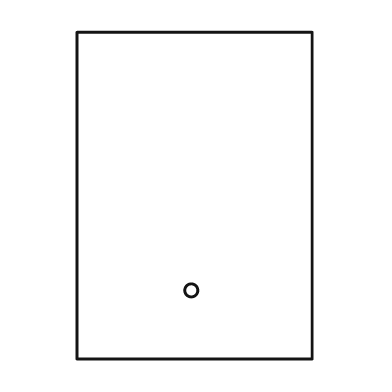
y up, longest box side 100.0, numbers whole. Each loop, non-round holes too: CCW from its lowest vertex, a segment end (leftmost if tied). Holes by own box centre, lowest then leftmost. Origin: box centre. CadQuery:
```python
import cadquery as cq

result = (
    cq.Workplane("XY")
    .moveTo(-36.0, -50.0)
    .lineTo(36.0, -50.0)
    .lineTo(36.0, 50.0)
    .lineTo(-36.0, 50.0)
    .close()
    .moveTo(-1.0, -29.0)
    .circle(2.0)
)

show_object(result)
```